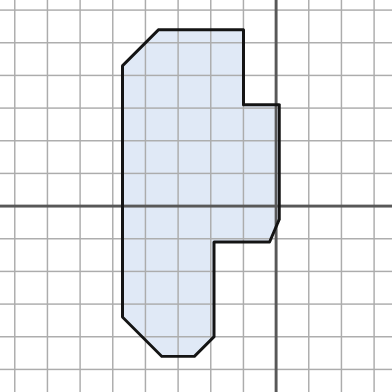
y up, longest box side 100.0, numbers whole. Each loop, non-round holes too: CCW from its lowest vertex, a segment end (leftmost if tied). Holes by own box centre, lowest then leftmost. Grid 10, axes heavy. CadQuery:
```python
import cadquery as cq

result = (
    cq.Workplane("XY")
    .moveTo(-35.0, -46.0)
    .lineTo(-25.0, -46.0)
    .lineTo(-19.0, -40.0)
    .lineTo(-19.0, -11.0)
    .lineTo(-2.0, -11.0)
    .lineTo(1.0, -4.0)
    .lineTo(1.0, 31.0)
    .lineTo(-10.0, 31.0)
    .lineTo(-10.0, 54.0)
    .lineTo(-36.0, 54.0)
    .lineTo(-47.0, 43.0)
    .lineTo(-47.0, -34.0)
    .close()
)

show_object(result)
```